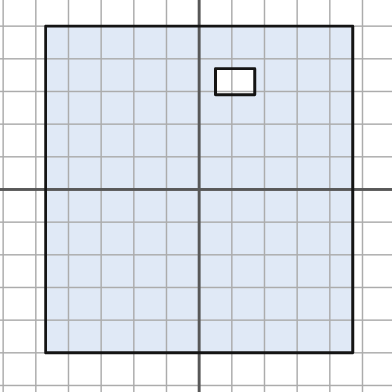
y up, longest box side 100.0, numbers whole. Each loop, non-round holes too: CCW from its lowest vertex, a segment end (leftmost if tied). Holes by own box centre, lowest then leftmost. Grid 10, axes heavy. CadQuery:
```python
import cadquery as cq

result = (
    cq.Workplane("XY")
    .moveTo(-47.0, -50.0)
    .lineTo(47.0, -50.0)
    .lineTo(47.0, 50.0)
    .lineTo(-47.0, 50.0)
    .close()
    .moveTo(5.0, 29.0)
    .lineTo(17.0, 29.0)
    .lineTo(17.0, 37.0)
    .lineTo(5.0, 37.0)
    .close()
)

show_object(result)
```